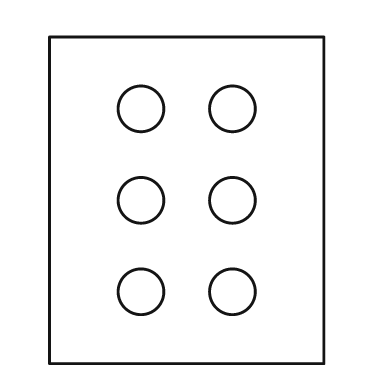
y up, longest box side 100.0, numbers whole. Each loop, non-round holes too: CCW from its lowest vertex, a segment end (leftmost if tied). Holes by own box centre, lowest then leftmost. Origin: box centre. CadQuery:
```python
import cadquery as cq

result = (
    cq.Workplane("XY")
    .moveTo(-42.0, -50.0)
    .lineTo(42.0, -50.0)
    .lineTo(42.0, 50.0)
    .lineTo(-42.0, 50.0)
    .close()
    .moveTo(-14.0, -28.0)
    .circle(7.0)
    .moveTo(14.0, -28.0)
    .circle(7.0)
    .moveTo(-14.0, 0.0)
    .circle(7.0)
    .moveTo(14.0, 0.0)
    .circle(7.0)
    .moveTo(-14.0, 28.0)
    .circle(7.0)
    .moveTo(14.0, 28.0)
    .circle(7.0)
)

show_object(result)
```